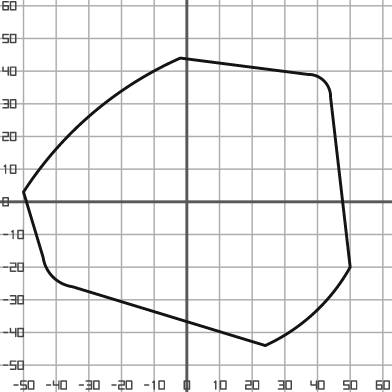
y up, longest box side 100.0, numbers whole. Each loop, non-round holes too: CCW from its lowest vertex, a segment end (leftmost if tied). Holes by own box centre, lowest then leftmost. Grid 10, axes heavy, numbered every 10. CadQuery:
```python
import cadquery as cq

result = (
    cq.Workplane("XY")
    .moveTo(24.0, -44.0)
    .threePointArc((39.0, -34.0), (50.0, -20.0))
    .lineTo(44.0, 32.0)
    .threePointArc((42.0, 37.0), (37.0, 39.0))
    .lineTo(-2.0, 44.0)
    .threePointArc((-29.0, 27.0), (-50.0, 3.0))
    .lineTo(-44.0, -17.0)
    .threePointArc((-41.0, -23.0), (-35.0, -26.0))
    .close()
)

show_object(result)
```